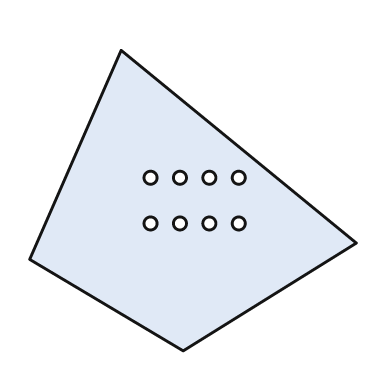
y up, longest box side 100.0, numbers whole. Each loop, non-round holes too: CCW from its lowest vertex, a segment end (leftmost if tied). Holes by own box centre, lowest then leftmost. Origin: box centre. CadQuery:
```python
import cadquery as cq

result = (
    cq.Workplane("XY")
    .moveTo(-3.0, -46.0)
    .lineTo(50.0, -13.0)
    .lineTo(-22.0, 46.0)
    .lineTo(-50.0, -18.0)
    .close()
    .moveTo(-13.0, -7.0)
    .circle(2.0)
    .moveTo(-4.0, -7.0)
    .circle(2.0)
    .moveTo(5.0, -7.0)
    .circle(2.0)
    .moveTo(14.0, -7.0)
    .circle(2.0)
    .moveTo(-13.0, 7.0)
    .circle(2.0)
    .moveTo(-4.0, 7.0)
    .circle(2.0)
    .moveTo(5.0, 7.0)
    .circle(2.0)
    .moveTo(14.0, 7.0)
    .circle(2.0)
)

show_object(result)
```